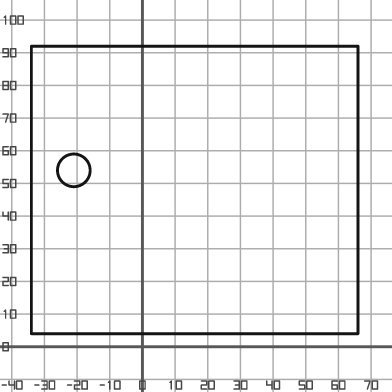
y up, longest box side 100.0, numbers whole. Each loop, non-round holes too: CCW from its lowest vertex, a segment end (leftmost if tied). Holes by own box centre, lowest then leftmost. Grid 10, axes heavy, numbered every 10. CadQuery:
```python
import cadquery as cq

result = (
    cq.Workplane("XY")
    .moveTo(-34.0, 4.0)
    .lineTo(66.0, 4.0)
    .lineTo(66.0, 92.0)
    .lineTo(-34.0, 92.0)
    .close()
    .moveTo(-21.0, 54.0)
    .circle(5.0)
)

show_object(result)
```